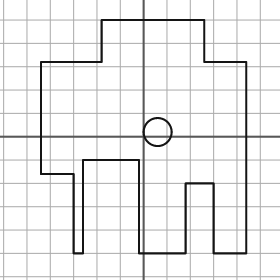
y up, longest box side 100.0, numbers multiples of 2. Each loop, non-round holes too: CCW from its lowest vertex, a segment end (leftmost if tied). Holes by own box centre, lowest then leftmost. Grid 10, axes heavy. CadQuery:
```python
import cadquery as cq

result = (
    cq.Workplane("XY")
    .moveTo(-30.0, -50.0)
    .lineTo(-26.0, -50.0)
    .lineTo(-26.0, -10.0)
    .lineTo(-2.0, -10.0)
    .lineTo(-2.0, -50.0)
    .lineTo(18.0, -50.0)
    .lineTo(18.0, -20.0)
    .lineTo(30.0, -20.0)
    .lineTo(30.0, -50.0)
    .lineTo(44.0, -50.0)
    .lineTo(44.0, 32.0)
    .lineTo(26.0, 32.0)
    .lineTo(26.0, 50.0)
    .lineTo(-18.0, 50.0)
    .lineTo(-18.0, 32.0)
    .lineTo(-44.0, 32.0)
    .lineTo(-44.0, -16.0)
    .lineTo(-30.0, -16.0)
    .close()
    .moveTo(6.0, 2.0)
    .circle(6.0)
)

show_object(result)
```